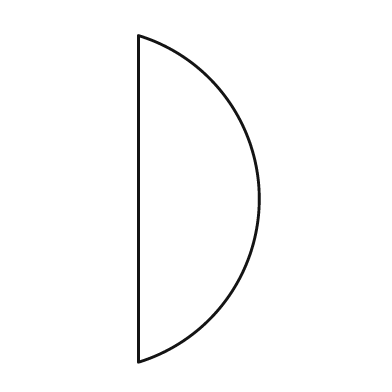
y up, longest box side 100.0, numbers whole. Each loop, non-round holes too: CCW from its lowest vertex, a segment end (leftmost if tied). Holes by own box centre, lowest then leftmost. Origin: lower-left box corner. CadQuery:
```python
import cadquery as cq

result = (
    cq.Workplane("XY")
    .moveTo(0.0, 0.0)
    .threePointArc((37.0, 50.0), (0.0, 100.0))
    .close()
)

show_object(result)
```